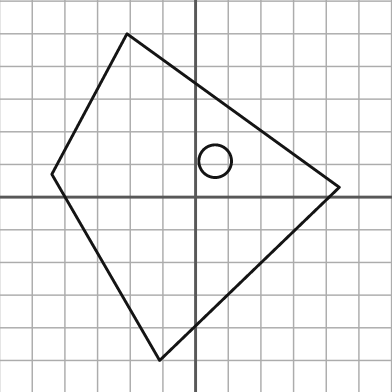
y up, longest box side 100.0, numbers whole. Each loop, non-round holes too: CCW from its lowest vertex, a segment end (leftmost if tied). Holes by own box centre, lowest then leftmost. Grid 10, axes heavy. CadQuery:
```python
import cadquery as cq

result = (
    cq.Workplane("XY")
    .moveTo(-11.0, -50.0)
    .lineTo(44.0, 3.0)
    .lineTo(-21.0, 50.0)
    .lineTo(-44.0, 7.0)
    .close()
    .moveTo(6.0, 11.0)
    .circle(5.0)
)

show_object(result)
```